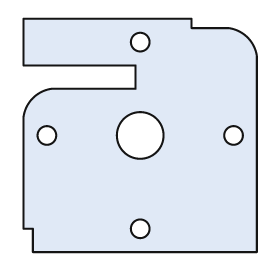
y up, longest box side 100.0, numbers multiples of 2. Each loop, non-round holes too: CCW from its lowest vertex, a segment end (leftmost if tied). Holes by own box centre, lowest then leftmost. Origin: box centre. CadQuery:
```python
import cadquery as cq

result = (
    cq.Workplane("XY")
    .moveTo(-46.0, -50.0)
    .lineTo(50.0, -50.0)
    .lineTo(50.0, 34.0)
    .threePointArc((46.0, 42.0), (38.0, 46.0))
    .lineTo(22.0, 46.0)
    .lineTo(22.0, 50.0)
    .lineTo(-50.0, 50.0)
    .lineTo(-50.0, 30.0)
    .lineTo(-2.0, 30.0)
    .lineTo(-2.0, 20.0)
    .lineTo(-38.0, 20.0)
    .threePointArc((-46.0, 16.0), (-50.0, 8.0))
    .lineTo(-50.0, -40.0)
    .lineTo(-46.0, -40.0)
    .close()
    .moveTo(0.0, -40.0)
    .circle(4.0)
    .moveTo(-40.0, 0.0)
    .circle(4.0)
    .moveTo(0.0, 0.0)
    .circle(10.0)
    .moveTo(40.0, 0.0)
    .circle(4.0)
    .moveTo(0.0, 40.0)
    .circle(4.0)
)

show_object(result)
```